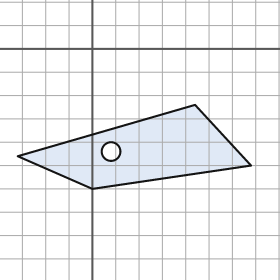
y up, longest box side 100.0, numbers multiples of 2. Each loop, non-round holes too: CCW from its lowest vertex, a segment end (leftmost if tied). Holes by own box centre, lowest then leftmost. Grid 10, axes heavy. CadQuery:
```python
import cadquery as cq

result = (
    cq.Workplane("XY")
    .moveTo(0.0, -60.0)
    .lineTo(68.0, -50.0)
    .lineTo(44.0, -24.0)
    .lineTo(-32.0, -46.0)
    .close()
    .moveTo(8.0, -44.0)
    .circle(4.0)
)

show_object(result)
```